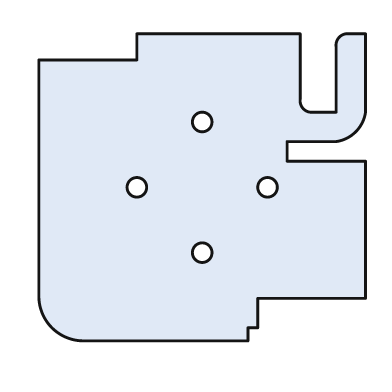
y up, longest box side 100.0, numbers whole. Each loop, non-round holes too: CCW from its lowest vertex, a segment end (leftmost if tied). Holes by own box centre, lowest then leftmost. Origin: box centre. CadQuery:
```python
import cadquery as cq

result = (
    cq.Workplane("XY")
    .moveTo(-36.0, -47.0)
    .lineTo(14.0, -47.0)
    .lineTo(14.0, -43.0)
    .lineTo(17.0, -43.0)
    .lineTo(17.0, -34.0)
    .lineTo(50.0, -34.0)
    .lineTo(50.0, 8.0)
    .lineTo(26.0, 8.0)
    .lineTo(26.0, 14.0)
    .lineTo(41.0, 14.0)
    .threePointArc((47.0, 17.0), (50.0, 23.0))
    .lineTo(50.0, 47.0)
    .lineTo(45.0, 47.0)
    .threePointArc((42.0, 46.0), (41.0, 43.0))
    .lineTo(41.0, 23.0)
    .lineTo(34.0, 23.0)
    .threePointArc((31.0, 24.0), (30.0, 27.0))
    .lineTo(30.0, 47.0)
    .lineTo(-20.0, 47.0)
    .lineTo(-20.0, 39.0)
    .lineTo(-50.0, 39.0)
    .lineTo(-50.0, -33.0)
    .threePointArc((-46.0, -43.0), (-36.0, -47.0))
    .close()
    .moveTo(0.0, -20.0)
    .circle(3.0)
    .moveTo(-20.0, 0.0)
    .circle(3.0)
    .moveTo(20.0, 0.0)
    .circle(3.0)
    .moveTo(0.0, 20.0)
    .circle(3.0)
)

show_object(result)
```